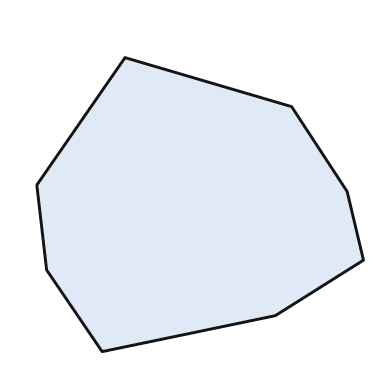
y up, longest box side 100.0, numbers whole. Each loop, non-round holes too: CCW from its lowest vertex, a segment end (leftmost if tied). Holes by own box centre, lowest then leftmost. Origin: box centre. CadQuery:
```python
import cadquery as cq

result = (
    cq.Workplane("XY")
    .moveTo(-30.0, -45.0)
    .lineTo(23.0, -34.0)
    .lineTo(50.0, -17.0)
    .lineTo(45.0, 4.0)
    .lineTo(28.0, 30.0)
    .lineTo(-23.0, 45.0)
    .lineTo(-50.0, 6.0)
    .lineTo(-47.0, -20.0)
    .close()
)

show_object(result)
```